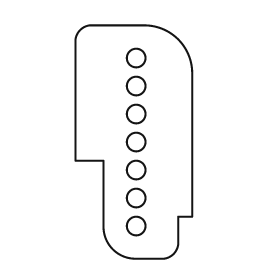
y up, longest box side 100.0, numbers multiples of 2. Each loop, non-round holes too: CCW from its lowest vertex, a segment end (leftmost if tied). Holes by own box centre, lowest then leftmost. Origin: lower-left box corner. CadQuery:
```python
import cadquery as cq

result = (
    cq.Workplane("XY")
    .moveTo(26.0, 0.0)
    .lineTo(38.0, 0.0)
    .threePointArc((42.0, 2.0), (44.0, 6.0))
    .lineTo(44.0, 18.0)
    .lineTo(50.0, 18.0)
    .lineTo(50.0, 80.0)
    .threePointArc((44.0, 94.0), (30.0, 100.0))
    .lineTo(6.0, 100.0)
    .threePointArc((2.0, 98.0), (0.0, 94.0))
    .lineTo(0.0, 42.0)
    .lineTo(12.0, 42.0)
    .lineTo(12.0, 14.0)
    .threePointArc((16.0, 4.0), (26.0, 0.0))
    .close()
    .moveTo(26.0, 14.0)
    .circle(4.0)
    .moveTo(26.0, 26.0)
    .circle(4.0)
    .moveTo(26.0, 38.0)
    .circle(4.0)
    .moveTo(26.0, 50.0)
    .circle(4.0)
    .moveTo(26.0, 62.0)
    .circle(4.0)
    .moveTo(26.0, 74.0)
    .circle(4.0)
    .moveTo(26.0, 86.0)
    .circle(4.0)
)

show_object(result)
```